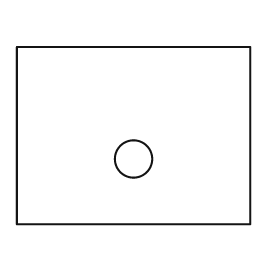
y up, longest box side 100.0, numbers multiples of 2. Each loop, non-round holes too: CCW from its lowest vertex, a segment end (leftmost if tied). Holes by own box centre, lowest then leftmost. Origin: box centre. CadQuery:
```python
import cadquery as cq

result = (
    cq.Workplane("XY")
    .moveTo(-50.0, -38.0)
    .lineTo(50.0, -38.0)
    .lineTo(50.0, 38.0)
    .lineTo(-50.0, 38.0)
    .close()
    .moveTo(0.0, -10.0)
    .circle(8.0)
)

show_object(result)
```